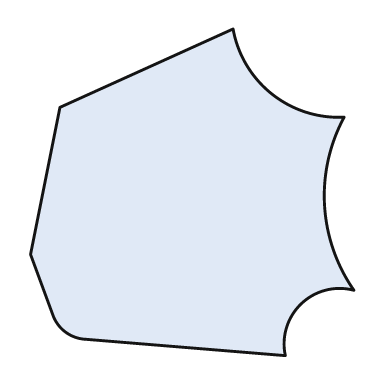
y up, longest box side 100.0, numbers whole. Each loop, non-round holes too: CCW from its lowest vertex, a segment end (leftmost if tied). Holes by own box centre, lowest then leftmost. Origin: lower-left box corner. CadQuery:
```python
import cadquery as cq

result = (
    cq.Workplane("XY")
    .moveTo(78.0, 0.0)
    .threePointArc((83.0, 16.0), (99.0, 20.0))
    .threePointArc((90.0, 46.0), (96.0, 73.0))
    .threePointArc((74.0, 80.0), (62.0, 100.0))
    .lineTo(9.0, 76.0)
    .lineTo(0.0, 31.0)
    .lineTo(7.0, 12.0)
    .threePointArc((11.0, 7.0), (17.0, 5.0))
    .close()
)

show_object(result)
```